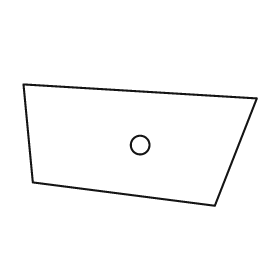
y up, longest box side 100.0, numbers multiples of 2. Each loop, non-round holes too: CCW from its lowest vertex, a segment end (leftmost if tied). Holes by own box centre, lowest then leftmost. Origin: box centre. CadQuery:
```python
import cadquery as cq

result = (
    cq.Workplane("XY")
    .moveTo(32.0, -26.0)
    .lineTo(50.0, 20.0)
    .lineTo(-50.0, 26.0)
    .lineTo(-46.0, -16.0)
    .close()
    .moveTo(0.0, 0.0)
    .circle(4.0)
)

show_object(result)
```